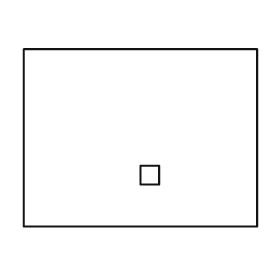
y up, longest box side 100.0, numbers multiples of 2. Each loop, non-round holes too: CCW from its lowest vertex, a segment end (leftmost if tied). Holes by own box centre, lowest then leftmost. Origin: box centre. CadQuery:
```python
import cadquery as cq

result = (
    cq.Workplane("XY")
    .moveTo(-50.0, -38.0)
    .lineTo(50.0, -38.0)
    .lineTo(50.0, 38.0)
    .lineTo(-50.0, 38.0)
    .close()
    .moveTo(0.0, -20.0)
    .lineTo(8.0, -20.0)
    .lineTo(8.0, -12.0)
    .lineTo(0.0, -12.0)
    .close()
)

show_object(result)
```